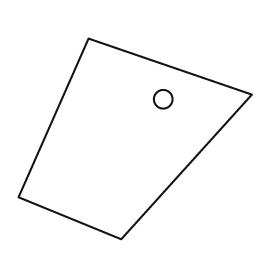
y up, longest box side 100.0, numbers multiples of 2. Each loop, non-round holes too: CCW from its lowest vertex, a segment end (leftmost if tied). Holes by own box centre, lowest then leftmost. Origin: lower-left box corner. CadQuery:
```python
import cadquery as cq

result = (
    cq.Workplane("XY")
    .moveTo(44.0, 0.0)
    .lineTo(100.0, 62.0)
    .lineTo(30.0, 86.0)
    .lineTo(0.0, 18.0)
    .close()
    .moveTo(62.0, 60.0)
    .circle(4.0)
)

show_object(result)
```